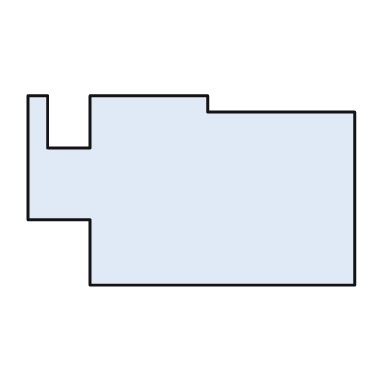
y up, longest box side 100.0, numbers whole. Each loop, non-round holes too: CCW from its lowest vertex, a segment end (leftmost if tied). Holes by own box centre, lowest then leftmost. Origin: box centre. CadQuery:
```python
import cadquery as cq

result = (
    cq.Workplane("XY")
    .moveTo(-31.0, -29.0)
    .lineTo(50.0, -29.0)
    .lineTo(50.0, 24.0)
    .lineTo(5.0, 24.0)
    .lineTo(5.0, 29.0)
    .lineTo(-31.0, 29.0)
    .lineTo(-31.0, 13.0)
    .lineTo(-44.0, 13.0)
    .lineTo(-44.0, 29.0)
    .lineTo(-50.0, 29.0)
    .lineTo(-50.0, -9.0)
    .lineTo(-31.0, -9.0)
    .close()
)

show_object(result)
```